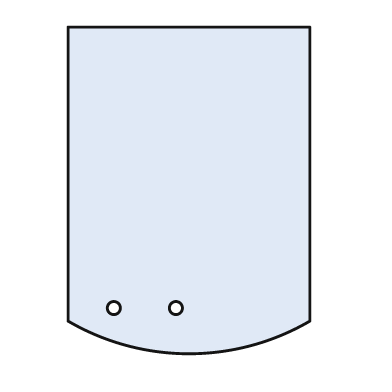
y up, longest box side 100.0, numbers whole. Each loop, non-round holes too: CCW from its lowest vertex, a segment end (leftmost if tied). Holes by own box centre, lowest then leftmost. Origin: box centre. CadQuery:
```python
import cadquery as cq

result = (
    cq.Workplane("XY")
    .moveTo(-37.0, -40.0)
    .threePointArc((0.0, -50.0), (37.0, -40.0))
    .lineTo(37.0, 50.0)
    .lineTo(-37.0, 50.0)
    .close()
    .moveTo(-23.0, -36.0)
    .circle(2.0)
    .moveTo(-4.0, -36.0)
    .circle(2.0)
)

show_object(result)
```